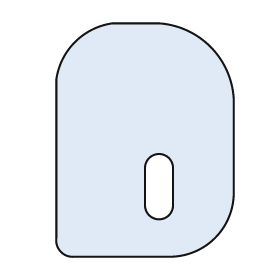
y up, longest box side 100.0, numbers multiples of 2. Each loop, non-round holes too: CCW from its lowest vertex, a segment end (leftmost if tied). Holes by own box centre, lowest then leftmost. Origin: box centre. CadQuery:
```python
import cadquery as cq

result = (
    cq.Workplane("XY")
    .moveTo(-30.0, -50.0)
    .lineTo(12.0, -50.0)
    .threePointArc((30.0, -42.0), (38.0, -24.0))
    .lineTo(38.0, 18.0)
    .threePointArc((28.0, 40.0), (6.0, 50.0))
    .lineTo(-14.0, 50.0)
    .threePointArc((-30.0, 42.0), (-38.0, 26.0))
    .lineTo(-38.0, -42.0)
    .threePointArc((-36.0, -48.0), (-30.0, -50.0))
    .close()
    .moveTo(0.0, -28.0)
    .threePointArc((6.0, -34.0), (12.0, -28.0))
    .lineTo(12.0, -12.0)
    .threePointArc((6.0, -6.0), (0.0, -12.0))
    .close()
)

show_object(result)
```